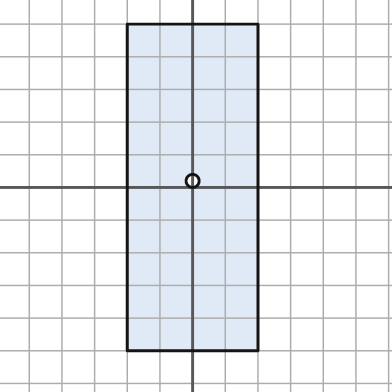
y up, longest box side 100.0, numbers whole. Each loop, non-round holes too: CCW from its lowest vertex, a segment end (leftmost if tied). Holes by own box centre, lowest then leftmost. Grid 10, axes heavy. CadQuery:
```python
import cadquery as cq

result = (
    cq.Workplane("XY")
    .moveTo(-20.0, -50.0)
    .lineTo(20.0, -50.0)
    .lineTo(20.0, 50.0)
    .lineTo(-20.0, 50.0)
    .close()
    .moveTo(0.0, 2.0)
    .circle(2.0)
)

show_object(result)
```